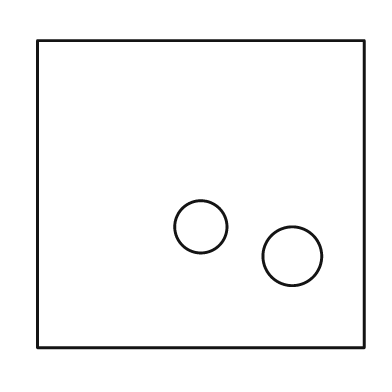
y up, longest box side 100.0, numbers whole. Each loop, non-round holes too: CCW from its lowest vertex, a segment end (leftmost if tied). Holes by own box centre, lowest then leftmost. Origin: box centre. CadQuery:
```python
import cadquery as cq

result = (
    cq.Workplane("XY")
    .moveTo(-50.0, -47.0)
    .lineTo(50.0, -47.0)
    .lineTo(50.0, 47.0)
    .lineTo(-50.0, 47.0)
    .close()
    .moveTo(28.0, -19.0)
    .circle(9.0)
    .moveTo(0.0, -10.0)
    .circle(8.0)
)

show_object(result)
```